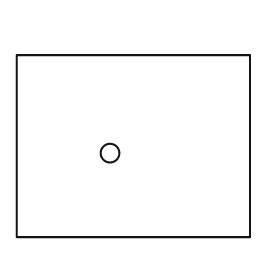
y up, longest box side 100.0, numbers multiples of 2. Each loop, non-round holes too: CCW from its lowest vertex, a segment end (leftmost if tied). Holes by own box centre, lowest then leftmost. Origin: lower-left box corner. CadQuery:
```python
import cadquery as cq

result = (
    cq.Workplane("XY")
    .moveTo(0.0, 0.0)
    .lineTo(100.0, 0.0)
    .lineTo(100.0, 78.0)
    .lineTo(0.0, 78.0)
    .close()
    .moveTo(40.0, 36.0)
    .circle(4.0)
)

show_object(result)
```